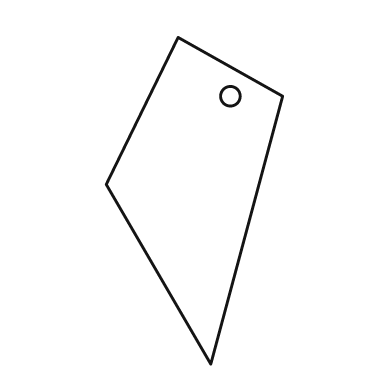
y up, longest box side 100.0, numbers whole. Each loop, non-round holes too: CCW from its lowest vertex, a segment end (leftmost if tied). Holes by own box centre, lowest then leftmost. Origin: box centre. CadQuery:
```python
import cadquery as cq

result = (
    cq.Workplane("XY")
    .moveTo(5.0, -50.0)
    .lineTo(27.0, 32.0)
    .lineTo(-5.0, 50.0)
    .lineTo(-27.0, 5.0)
    .close()
    .moveTo(11.0, 32.0)
    .circle(3.0)
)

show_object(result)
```